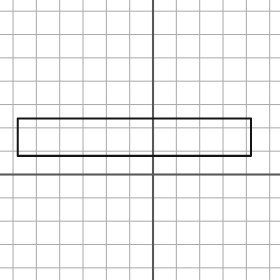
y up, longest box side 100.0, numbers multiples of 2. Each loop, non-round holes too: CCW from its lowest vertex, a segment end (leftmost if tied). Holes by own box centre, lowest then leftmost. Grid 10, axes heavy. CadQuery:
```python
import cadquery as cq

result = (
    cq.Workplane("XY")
    .moveTo(-58.0, 8.0)
    .lineTo(42.0, 8.0)
    .lineTo(42.0, 24.0)
    .lineTo(-58.0, 24.0)
    .close()
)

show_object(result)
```